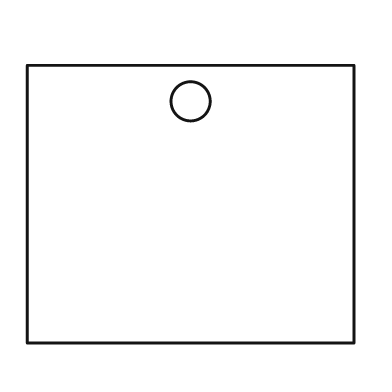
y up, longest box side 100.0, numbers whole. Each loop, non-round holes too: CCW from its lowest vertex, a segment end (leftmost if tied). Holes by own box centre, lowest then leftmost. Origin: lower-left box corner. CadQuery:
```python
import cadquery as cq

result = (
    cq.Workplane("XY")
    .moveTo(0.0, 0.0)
    .lineTo(100.0, 0.0)
    .lineTo(100.0, 85.0)
    .lineTo(0.0, 85.0)
    .close()
    .moveTo(50.0, 74.0)
    .circle(6.0)
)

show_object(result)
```